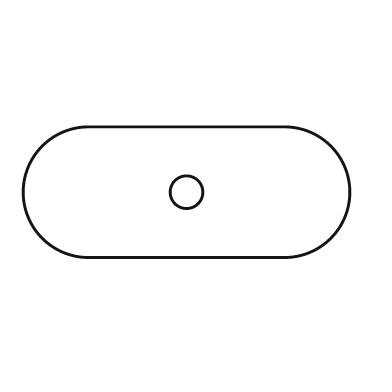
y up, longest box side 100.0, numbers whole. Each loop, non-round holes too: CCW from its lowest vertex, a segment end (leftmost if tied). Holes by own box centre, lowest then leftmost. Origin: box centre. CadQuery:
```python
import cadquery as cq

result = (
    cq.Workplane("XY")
    .moveTo(-30.0, -20.0)
    .lineTo(30.0, -20.0)
    .threePointArc((50.0, 0.0), (30.0, 20.0))
    .lineTo(-30.0, 20.0)
    .threePointArc((-50.0, 0.0), (-30.0, -20.0))
    .close()
    .moveTo(0.0, 0.0)
    .circle(5.0)
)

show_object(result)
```